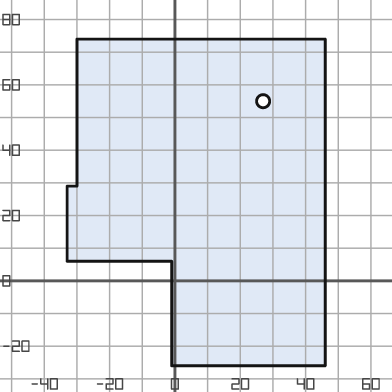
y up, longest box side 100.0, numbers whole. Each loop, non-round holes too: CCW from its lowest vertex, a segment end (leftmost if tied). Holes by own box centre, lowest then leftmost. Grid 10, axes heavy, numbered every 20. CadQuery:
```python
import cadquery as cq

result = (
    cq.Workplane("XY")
    .moveTo(-1.0, -26.0)
    .lineTo(46.0, -26.0)
    .lineTo(46.0, 74.0)
    .lineTo(-30.0, 74.0)
    .lineTo(-30.0, 29.0)
    .lineTo(-33.0, 29.0)
    .lineTo(-33.0, 6.0)
    .lineTo(-1.0, 6.0)
    .close()
    .moveTo(27.0, 55.0)
    .circle(2.0)
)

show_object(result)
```